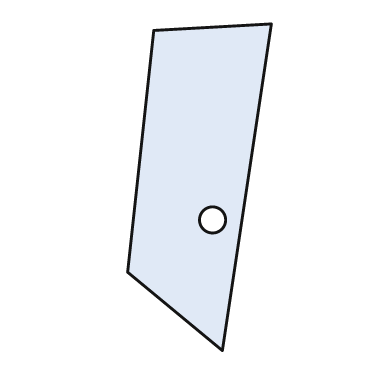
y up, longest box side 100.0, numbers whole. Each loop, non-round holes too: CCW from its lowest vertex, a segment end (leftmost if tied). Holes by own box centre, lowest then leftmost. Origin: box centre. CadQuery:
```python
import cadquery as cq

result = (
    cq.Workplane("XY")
    .moveTo(7.0, -50.0)
    .lineTo(22.0, 50.0)
    .lineTo(-14.0, 48.0)
    .lineTo(-22.0, -26.0)
    .close()
    .moveTo(4.0, -10.0)
    .circle(4.0)
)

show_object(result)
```